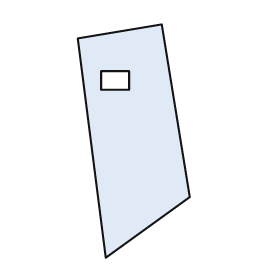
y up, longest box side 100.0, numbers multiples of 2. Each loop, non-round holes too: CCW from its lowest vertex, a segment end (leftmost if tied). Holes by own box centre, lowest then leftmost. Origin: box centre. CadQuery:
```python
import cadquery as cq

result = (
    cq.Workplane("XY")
    .moveTo(-12.0, -50.0)
    .lineTo(24.0, -24.0)
    .lineTo(12.0, 50.0)
    .lineTo(-24.0, 44.0)
    .close()
    .moveTo(-14.0, 22.0)
    .lineTo(-2.0, 22.0)
    .lineTo(-2.0, 30.0)
    .lineTo(-14.0, 30.0)
    .close()
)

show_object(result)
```